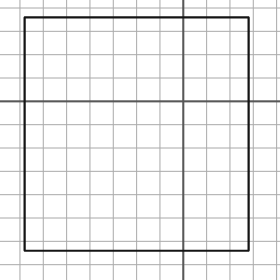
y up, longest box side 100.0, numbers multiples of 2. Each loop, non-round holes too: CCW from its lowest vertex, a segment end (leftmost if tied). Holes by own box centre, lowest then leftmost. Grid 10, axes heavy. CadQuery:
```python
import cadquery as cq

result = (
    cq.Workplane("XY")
    .moveTo(-68.0, -64.0)
    .lineTo(28.0, -64.0)
    .lineTo(28.0, 36.0)
    .lineTo(-68.0, 36.0)
    .close()
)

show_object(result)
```